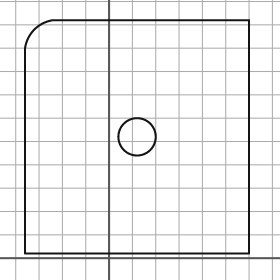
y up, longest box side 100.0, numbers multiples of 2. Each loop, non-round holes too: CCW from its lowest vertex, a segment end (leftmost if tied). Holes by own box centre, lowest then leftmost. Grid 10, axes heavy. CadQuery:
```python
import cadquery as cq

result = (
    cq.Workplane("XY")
    .moveTo(-36.0, 2.0)
    .lineTo(60.0, 2.0)
    .lineTo(60.0, 102.0)
    .lineTo(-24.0, 102.0)
    .threePointArc((-32.0, 98.0), (-36.0, 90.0))
    .close()
    .moveTo(12.0, 52.0)
    .circle(8.0)
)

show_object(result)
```